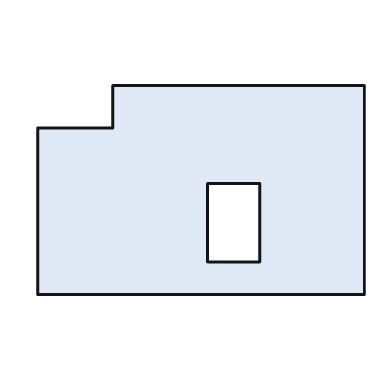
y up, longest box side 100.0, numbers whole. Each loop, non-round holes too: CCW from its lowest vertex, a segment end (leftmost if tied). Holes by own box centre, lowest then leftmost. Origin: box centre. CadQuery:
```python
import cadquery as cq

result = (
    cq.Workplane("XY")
    .moveTo(-50.0, -32.0)
    .lineTo(50.0, -32.0)
    .lineTo(50.0, 32.0)
    .lineTo(-27.0, 32.0)
    .lineTo(-27.0, 19.0)
    .lineTo(-50.0, 19.0)
    .close()
    .moveTo(2.0, -22.0)
    .lineTo(18.0, -22.0)
    .lineTo(18.0, 2.0)
    .lineTo(2.0, 2.0)
    .close()
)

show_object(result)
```